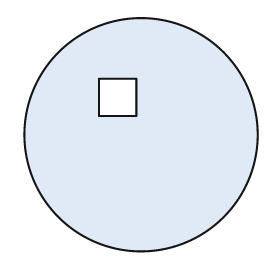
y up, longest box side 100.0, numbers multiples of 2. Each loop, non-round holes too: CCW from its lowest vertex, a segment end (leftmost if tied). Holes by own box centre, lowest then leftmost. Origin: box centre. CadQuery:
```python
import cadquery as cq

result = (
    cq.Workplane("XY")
    .moveTo(0.0, 0.0)
    .circle(50.0)
    .moveTo(-18.0, 8.0)
    .lineTo(-2.0, 8.0)
    .lineTo(-2.0, 24.0)
    .lineTo(-18.0, 24.0)
    .close()
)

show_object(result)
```